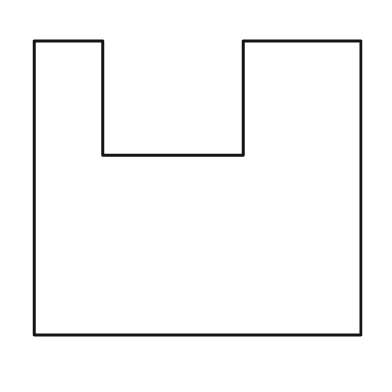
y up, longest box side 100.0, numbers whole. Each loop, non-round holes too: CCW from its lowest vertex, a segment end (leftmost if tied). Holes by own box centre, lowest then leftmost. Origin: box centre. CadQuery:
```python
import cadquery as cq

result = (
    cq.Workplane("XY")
    .moveTo(-50.0, -45.0)
    .lineTo(50.0, -45.0)
    .lineTo(50.0, 45.0)
    .lineTo(14.0, 45.0)
    .lineTo(14.0, 10.0)
    .lineTo(-29.0, 10.0)
    .lineTo(-29.0, 45.0)
    .lineTo(-50.0, 45.0)
    .close()
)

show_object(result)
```